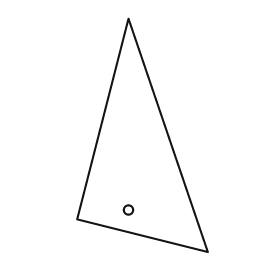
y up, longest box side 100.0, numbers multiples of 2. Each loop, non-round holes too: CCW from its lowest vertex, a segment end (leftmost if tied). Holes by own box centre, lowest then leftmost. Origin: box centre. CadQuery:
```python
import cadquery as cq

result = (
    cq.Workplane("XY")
    .moveTo(28.0, -50.0)
    .lineTo(-6.0, 50.0)
    .lineTo(-28.0, -36.0)
    .close()
    .moveTo(-6.0, -32.0)
    .circle(2.0)
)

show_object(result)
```